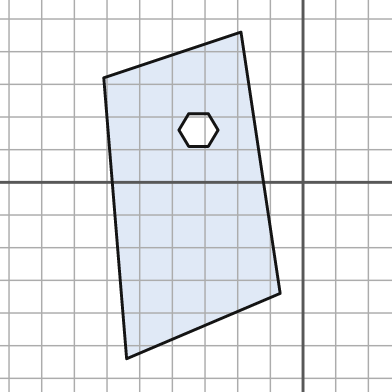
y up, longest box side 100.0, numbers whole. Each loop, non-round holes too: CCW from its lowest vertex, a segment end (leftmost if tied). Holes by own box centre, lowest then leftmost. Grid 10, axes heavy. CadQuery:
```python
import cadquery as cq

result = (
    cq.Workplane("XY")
    .moveTo(-54.0, -54.0)
    .lineTo(-7.0, -34.0)
    .lineTo(-19.0, 46.0)
    .lineTo(-61.0, 32.0)
    .close()
    .moveTo(-35.0, 11.0)
    .lineTo(-29.0, 11.0)
    .lineTo(-26.0, 16.0)
    .lineTo(-29.0, 21.0)
    .lineTo(-35.0, 21.0)
    .lineTo(-38.0, 16.0)
    .close()
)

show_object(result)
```